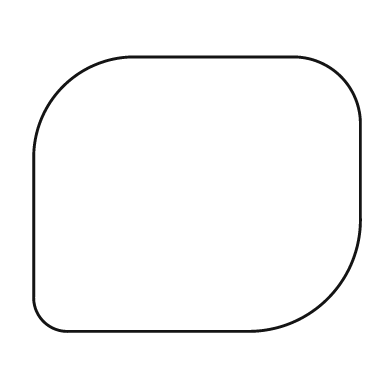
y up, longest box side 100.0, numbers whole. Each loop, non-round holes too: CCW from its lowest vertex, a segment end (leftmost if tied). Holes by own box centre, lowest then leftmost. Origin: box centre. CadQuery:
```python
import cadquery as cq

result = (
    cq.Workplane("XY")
    .moveTo(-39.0, -42.0)
    .lineTo(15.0, -42.0)
    .threePointArc((40.0, -32.0), (50.0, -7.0))
    .lineTo(50.0, 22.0)
    .threePointArc((44.0, 36.0), (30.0, 42.0))
    .lineTo(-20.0, 42.0)
    .threePointArc((-41.0, 33.0), (-50.0, 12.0))
    .lineTo(-50.0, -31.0)
    .threePointArc((-47.0, -39.0), (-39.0, -42.0))
    .close()
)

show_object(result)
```